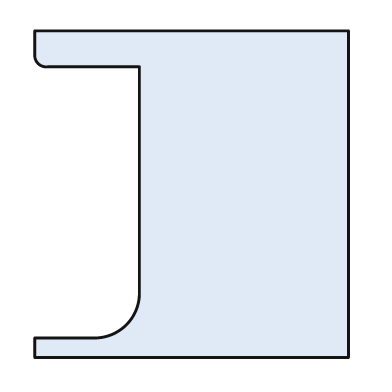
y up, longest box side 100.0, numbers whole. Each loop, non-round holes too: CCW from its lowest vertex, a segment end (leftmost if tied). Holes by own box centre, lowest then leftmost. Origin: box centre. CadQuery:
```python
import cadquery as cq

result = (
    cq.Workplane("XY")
    .moveTo(-48.0, -50.0)
    .lineTo(48.0, -50.0)
    .lineTo(48.0, 50.0)
    .lineTo(-48.0, 50.0)
    .lineTo(-48.0, 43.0)
    .threePointArc((-47.0, 40.0), (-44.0, 39.0))
    .lineTo(-16.0, 39.0)
    .lineTo(-16.0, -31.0)
    .threePointArc((-20.0, -40.0), (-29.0, -44.0))
    .lineTo(-48.0, -44.0)
    .close()
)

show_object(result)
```